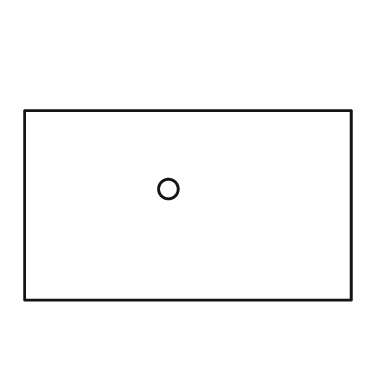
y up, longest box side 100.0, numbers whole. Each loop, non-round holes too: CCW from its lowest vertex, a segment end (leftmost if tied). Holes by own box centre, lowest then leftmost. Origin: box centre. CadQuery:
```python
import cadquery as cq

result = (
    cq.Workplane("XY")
    .moveTo(-50.0, -29.0)
    .lineTo(50.0, -29.0)
    .lineTo(50.0, 29.0)
    .lineTo(-50.0, 29.0)
    .close()
    .moveTo(-6.0, 5.0)
    .circle(3.0)
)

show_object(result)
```